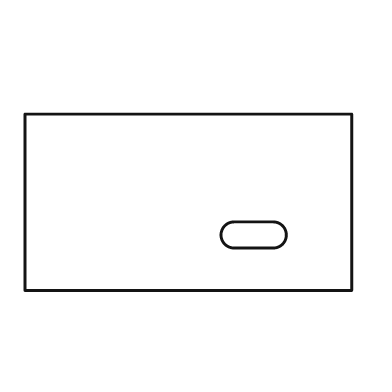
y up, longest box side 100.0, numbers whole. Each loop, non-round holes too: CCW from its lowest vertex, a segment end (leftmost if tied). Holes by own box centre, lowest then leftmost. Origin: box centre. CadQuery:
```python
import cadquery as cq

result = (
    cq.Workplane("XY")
    .moveTo(-50.0, -27.0)
    .lineTo(50.0, -27.0)
    .lineTo(50.0, 27.0)
    .lineTo(-50.0, 27.0)
    .close()
    .moveTo(14.0, -14.0)
    .lineTo(26.0, -14.0)
    .threePointArc((30.0, -10.0), (26.0, -6.0))
    .lineTo(14.0, -6.0)
    .threePointArc((10.0, -10.0), (14.0, -14.0))
    .close()
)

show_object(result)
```